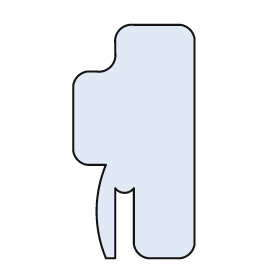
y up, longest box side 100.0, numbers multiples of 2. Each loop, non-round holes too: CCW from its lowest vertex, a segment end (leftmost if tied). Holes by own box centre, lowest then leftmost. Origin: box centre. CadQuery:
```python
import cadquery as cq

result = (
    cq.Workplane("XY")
    .moveTo(-12.0, -50.0)
    .lineTo(-8.0, -50.0)
    .lineTo(-8.0, -20.0)
    .threePointArc((-4.0, -22.0), (0.0, -20.0))
    .lineTo(0.0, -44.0)
    .threePointArc((2.0, -48.0), (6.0, -50.0))
    .lineTo(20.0, -50.0)
    .threePointArc((24.0, -48.0), (26.0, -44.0))
    .lineTo(26.0, 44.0)
    .threePointArc((24.0, 48.0), (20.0, 50.0))
    .lineTo(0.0, 50.0)
    .threePointArc((-6.0, 48.0), (-8.0, 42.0))
    .lineTo(-8.0, 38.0)
    .threePointArc((-10.0, 32.0), (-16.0, 30.0))
    .lineTo(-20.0, 30.0)
    .threePointArc((-24.0, 28.0), (-26.0, 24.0))
    .lineTo(-26.0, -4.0)
    .threePointArc((-24.0, -8.0), (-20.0, -10.0))
    .lineTo(-12.0, -10.0)
    .threePointArc((-16.0, -30.0), (-12.0, -50.0))
    .close()
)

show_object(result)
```